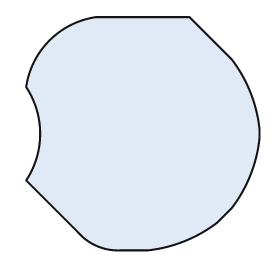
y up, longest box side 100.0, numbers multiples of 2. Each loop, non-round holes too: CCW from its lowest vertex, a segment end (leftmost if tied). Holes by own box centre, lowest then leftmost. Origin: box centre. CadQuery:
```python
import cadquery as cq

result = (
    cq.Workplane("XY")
    .moveTo(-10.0, -50.0)
    .lineTo(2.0, -50.0)
    .threePointArc((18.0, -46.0), (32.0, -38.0))
    .lineTo(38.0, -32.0)
    .threePointArc((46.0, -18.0), (50.0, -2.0))
    .lineTo(50.0, 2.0)
    .threePointArc((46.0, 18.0), (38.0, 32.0))
    .lineTo(20.0, 50.0)
    .lineTo(-20.0, 50.0)
    .threePointArc((-40.0, 40.0), (-50.0, 20.0))
    .threePointArc((-44.0, 0.0), (-50.0, -20.0))
    .lineTo(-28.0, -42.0)
    .threePointArc((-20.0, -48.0), (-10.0, -50.0))
    .close()
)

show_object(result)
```